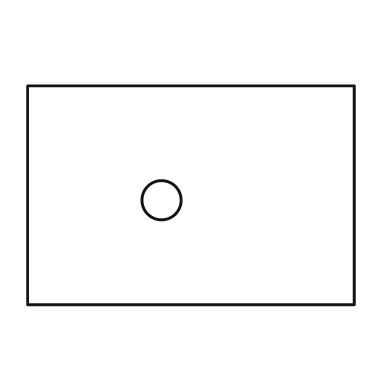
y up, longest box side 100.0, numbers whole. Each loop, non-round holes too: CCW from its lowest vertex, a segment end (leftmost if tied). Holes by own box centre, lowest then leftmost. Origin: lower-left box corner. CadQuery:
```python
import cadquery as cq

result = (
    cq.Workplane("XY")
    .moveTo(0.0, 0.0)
    .lineTo(100.0, 0.0)
    .lineTo(100.0, 67.0)
    .lineTo(0.0, 67.0)
    .close()
    .moveTo(41.0, 32.0)
    .circle(6.0)
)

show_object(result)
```